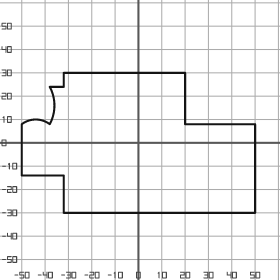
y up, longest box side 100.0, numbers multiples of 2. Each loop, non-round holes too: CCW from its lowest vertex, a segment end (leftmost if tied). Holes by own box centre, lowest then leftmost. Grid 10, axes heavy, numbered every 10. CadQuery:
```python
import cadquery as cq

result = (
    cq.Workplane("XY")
    .moveTo(-32.0, -30.0)
    .lineTo(50.0, -30.0)
    .lineTo(50.0, 8.0)
    .lineTo(20.0, 8.0)
    .lineTo(20.0, 30.0)
    .lineTo(-32.0, 30.0)
    .lineTo(-32.0, 24.0)
    .lineTo(-38.0, 24.0)
    .threePointArc((-36.0, 16.0), (-38.0, 8.0))
    .threePointArc((-44.0, 10.0), (-50.0, 8.0))
    .lineTo(-50.0, -14.0)
    .lineTo(-32.0, -14.0)
    .close()
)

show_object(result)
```